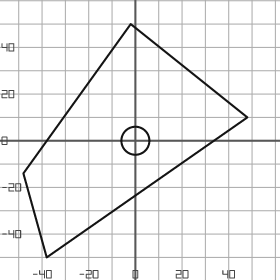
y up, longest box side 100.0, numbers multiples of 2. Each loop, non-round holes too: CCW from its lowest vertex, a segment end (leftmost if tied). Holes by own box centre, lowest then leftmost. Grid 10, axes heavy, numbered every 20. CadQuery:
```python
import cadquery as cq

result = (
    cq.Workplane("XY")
    .moveTo(-38.0, -50.0)
    .lineTo(48.0, 10.0)
    .lineTo(-2.0, 50.0)
    .lineTo(-48.0, -14.0)
    .close()
    .moveTo(0.0, 0.0)
    .circle(6.0)
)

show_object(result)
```